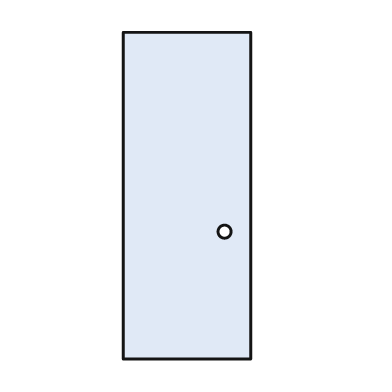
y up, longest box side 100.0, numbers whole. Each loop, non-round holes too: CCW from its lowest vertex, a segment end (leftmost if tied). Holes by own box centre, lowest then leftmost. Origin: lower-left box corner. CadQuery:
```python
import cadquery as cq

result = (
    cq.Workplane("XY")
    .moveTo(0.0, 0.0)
    .lineTo(39.0, 0.0)
    .lineTo(39.0, 100.0)
    .lineTo(0.0, 100.0)
    .close()
    .moveTo(31.0, 39.0)
    .circle(2.0)
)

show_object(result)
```